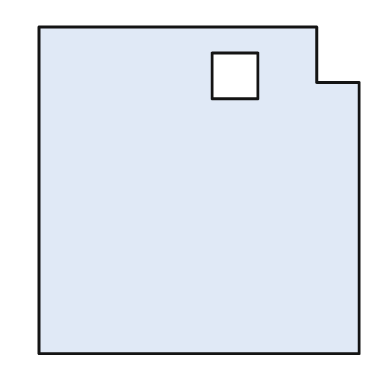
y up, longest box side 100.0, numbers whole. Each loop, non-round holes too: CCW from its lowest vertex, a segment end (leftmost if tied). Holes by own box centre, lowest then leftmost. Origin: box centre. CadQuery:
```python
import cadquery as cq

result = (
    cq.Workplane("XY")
    .moveTo(-49.0, -50.0)
    .lineTo(49.0, -50.0)
    .lineTo(49.0, 33.0)
    .lineTo(36.0, 33.0)
    .lineTo(36.0, 50.0)
    .lineTo(-49.0, 50.0)
    .close()
    .moveTo(4.0, 28.0)
    .lineTo(18.0, 28.0)
    .lineTo(18.0, 42.0)
    .lineTo(4.0, 42.0)
    .close()
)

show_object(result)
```